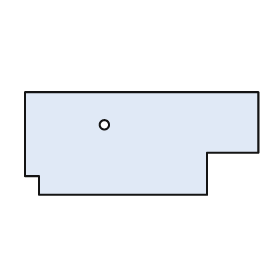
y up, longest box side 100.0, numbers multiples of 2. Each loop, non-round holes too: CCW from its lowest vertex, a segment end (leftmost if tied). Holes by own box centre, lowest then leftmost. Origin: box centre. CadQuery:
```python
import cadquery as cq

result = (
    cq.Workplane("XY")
    .moveTo(-44.0, -22.0)
    .lineTo(28.0, -22.0)
    .lineTo(28.0, -4.0)
    .lineTo(50.0, -4.0)
    .lineTo(50.0, 22.0)
    .lineTo(-50.0, 22.0)
    .lineTo(-50.0, -14.0)
    .lineTo(-44.0, -14.0)
    .close()
    .moveTo(-16.0, 8.0)
    .circle(2.0)
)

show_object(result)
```